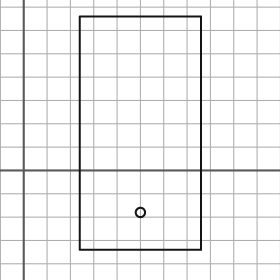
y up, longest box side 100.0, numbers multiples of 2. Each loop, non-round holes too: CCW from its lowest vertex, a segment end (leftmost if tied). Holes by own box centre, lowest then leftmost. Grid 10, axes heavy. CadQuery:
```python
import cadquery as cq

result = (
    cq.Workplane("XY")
    .moveTo(24.0, -34.0)
    .lineTo(76.0, -34.0)
    .lineTo(76.0, 66.0)
    .lineTo(24.0, 66.0)
    .close()
    .moveTo(50.0, -18.0)
    .circle(2.0)
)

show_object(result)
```